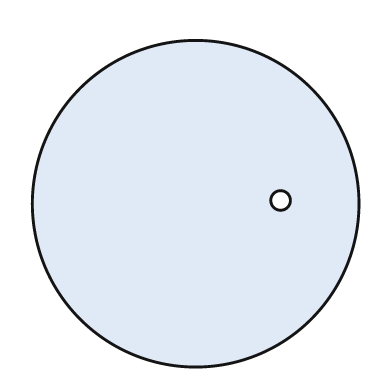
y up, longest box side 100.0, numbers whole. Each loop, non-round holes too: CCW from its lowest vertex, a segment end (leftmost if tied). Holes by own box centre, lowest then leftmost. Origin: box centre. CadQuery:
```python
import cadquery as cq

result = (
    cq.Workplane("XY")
    .moveTo(0.0, 0.0)
    .circle(50.0)
    .moveTo(26.0, 1.0)
    .circle(3.0)
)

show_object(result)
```